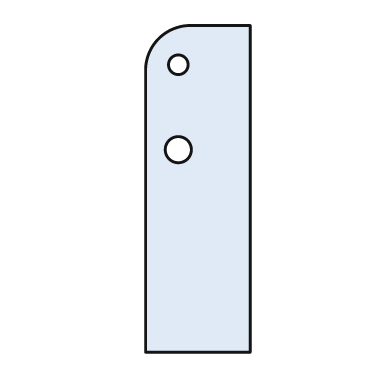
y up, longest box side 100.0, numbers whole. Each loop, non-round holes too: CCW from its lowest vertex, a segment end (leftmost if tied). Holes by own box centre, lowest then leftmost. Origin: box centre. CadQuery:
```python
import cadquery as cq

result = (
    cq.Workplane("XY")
    .moveTo(-16.0, -50.0)
    .lineTo(16.0, -50.0)
    .lineTo(16.0, 50.0)
    .lineTo(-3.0, 50.0)
    .threePointArc((-12.0, 46.0), (-16.0, 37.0))
    .close()
    .moveTo(-6.0, 12.0)
    .circle(4.0)
    .moveTo(-6.0, 38.0)
    .circle(3.0)
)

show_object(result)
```